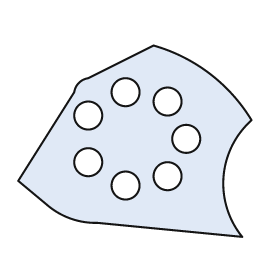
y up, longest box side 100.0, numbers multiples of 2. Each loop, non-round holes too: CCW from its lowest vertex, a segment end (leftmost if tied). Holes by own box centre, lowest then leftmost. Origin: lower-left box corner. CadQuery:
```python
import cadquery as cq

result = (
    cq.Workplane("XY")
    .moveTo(96.0, 0.0)
    .threePointArc((88.0, 26.0), (100.0, 50.0))
    .threePointArc((82.0, 70.0), (58.0, 82.0))
    .lineTo(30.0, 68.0)
    .threePointArc((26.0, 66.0), (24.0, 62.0))
    .lineTo(0.0, 24.0)
    .lineTo(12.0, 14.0)
    .threePointArc((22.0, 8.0), (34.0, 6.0))
    .close()
    .moveTo(46.0, 22.0)
    .circle(6.0)
    .moveTo(64.0, 26.0)
    .circle(6.0)
    .moveTo(30.0, 32.0)
    .circle(6.0)
    .moveTo(72.0, 42.0)
    .circle(6.0)
    .moveTo(30.0, 52.0)
    .circle(6.0)
    .moveTo(64.0, 58.0)
    .circle(6.0)
    .moveTo(46.0, 62.0)
    .circle(6.0)
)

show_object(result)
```